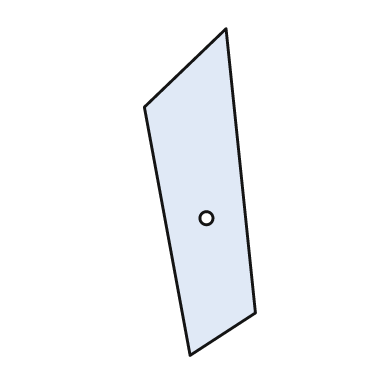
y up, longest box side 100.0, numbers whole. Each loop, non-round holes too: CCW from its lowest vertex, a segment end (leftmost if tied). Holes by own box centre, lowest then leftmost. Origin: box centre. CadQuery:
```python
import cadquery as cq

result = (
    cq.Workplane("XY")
    .moveTo(-3.0, -50.0)
    .lineTo(17.0, -37.0)
    .lineTo(8.0, 50.0)
    .lineTo(-17.0, 26.0)
    .close()
    .moveTo(2.0, -8.0)
    .circle(2.0)
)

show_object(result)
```